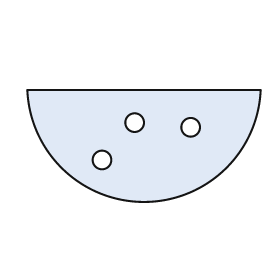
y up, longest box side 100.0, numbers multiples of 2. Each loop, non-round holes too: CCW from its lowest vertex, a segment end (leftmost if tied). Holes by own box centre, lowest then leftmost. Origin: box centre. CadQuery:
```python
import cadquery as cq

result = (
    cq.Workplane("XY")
    .moveTo(-50.0, 24.0)
    .threePointArc((0.0, -24.0), (50.0, 24.0))
    .close()
    .moveTo(-18.0, -6.0)
    .circle(4.0)
    .moveTo(20.0, 8.0)
    .circle(4.0)
    .moveTo(-4.0, 10.0)
    .circle(4.0)
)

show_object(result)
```